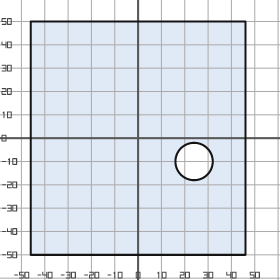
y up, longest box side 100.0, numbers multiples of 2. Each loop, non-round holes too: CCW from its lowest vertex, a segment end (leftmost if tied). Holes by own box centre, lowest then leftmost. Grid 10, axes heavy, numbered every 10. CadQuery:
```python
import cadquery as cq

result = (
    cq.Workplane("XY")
    .moveTo(-46.0, -50.0)
    .lineTo(46.0, -50.0)
    .lineTo(46.0, 50.0)
    .lineTo(-46.0, 50.0)
    .close()
    .moveTo(24.0, -10.0)
    .circle(8.0)
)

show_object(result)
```